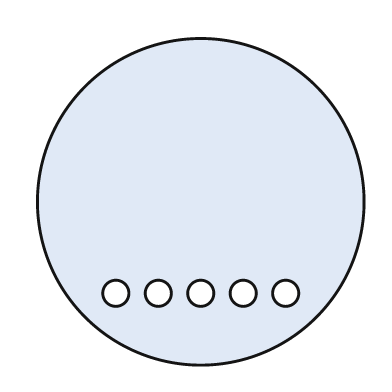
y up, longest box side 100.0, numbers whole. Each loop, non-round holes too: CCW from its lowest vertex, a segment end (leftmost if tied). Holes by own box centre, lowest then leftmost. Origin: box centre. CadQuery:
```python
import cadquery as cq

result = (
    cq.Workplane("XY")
    .moveTo(0.0, 0.0)
    .circle(50.0)
    .moveTo(-26.0, -28.0)
    .circle(4.0)
    .moveTo(-13.0, -28.0)
    .circle(4.0)
    .moveTo(0.0, -28.0)
    .circle(4.0)
    .moveTo(13.0, -28.0)
    .circle(4.0)
    .moveTo(26.0, -28.0)
    .circle(4.0)
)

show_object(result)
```